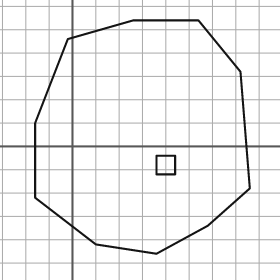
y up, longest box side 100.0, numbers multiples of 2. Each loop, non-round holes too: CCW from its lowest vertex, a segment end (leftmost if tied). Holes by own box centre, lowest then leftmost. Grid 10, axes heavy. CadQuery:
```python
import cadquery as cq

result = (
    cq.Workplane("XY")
    .moveTo(36.0, -46.0)
    .lineTo(58.0, -34.0)
    .lineTo(76.0, -18.0)
    .lineTo(72.0, 32.0)
    .lineTo(54.0, 54.0)
    .lineTo(26.0, 54.0)
    .lineTo(-2.0, 46.0)
    .lineTo(-16.0, 10.0)
    .lineTo(-16.0, -22.0)
    .lineTo(10.0, -42.0)
    .close()
    .moveTo(36.0, -12.0)
    .lineTo(44.0, -12.0)
    .lineTo(44.0, -4.0)
    .lineTo(36.0, -4.0)
    .close()
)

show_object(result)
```